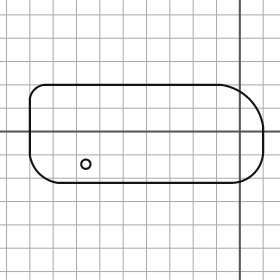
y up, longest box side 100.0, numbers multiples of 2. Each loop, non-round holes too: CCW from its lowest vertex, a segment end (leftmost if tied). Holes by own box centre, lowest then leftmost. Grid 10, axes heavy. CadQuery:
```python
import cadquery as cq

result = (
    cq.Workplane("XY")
    .moveTo(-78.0, -22.0)
    .lineTo(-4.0, -22.0)
    .threePointArc((6.0, -18.0), (10.0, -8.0))
    .lineTo(10.0, 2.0)
    .threePointArc((4.0, 14.0), (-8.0, 20.0))
    .lineTo(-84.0, 20.0)
    .threePointArc((-88.0, 18.0), (-90.0, 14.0))
    .lineTo(-90.0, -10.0)
    .threePointArc((-86.0, -18.0), (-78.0, -22.0))
    .close()
    .moveTo(-66.0, -14.0)
    .circle(2.0)
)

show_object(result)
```